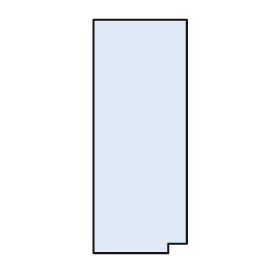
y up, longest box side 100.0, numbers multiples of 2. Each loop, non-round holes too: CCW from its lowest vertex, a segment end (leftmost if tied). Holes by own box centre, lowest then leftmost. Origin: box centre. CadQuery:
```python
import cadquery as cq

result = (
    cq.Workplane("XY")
    .moveTo(-20.0, -50.0)
    .lineTo(12.0, -50.0)
    .lineTo(12.0, -46.0)
    .lineTo(20.0, -46.0)
    .lineTo(20.0, 50.0)
    .lineTo(-20.0, 50.0)
    .close()
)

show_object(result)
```